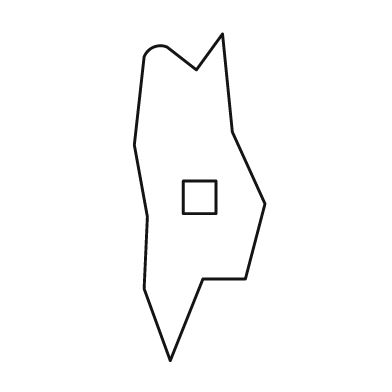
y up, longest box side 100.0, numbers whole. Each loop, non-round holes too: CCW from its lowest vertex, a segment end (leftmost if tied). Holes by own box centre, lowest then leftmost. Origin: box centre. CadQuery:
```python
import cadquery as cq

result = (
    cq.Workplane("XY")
    .moveTo(-9.0, -50.0)
    .lineTo(1.0, -25.0)
    .lineTo(14.0, -25.0)
    .lineTo(20.0, -2.0)
    .lineTo(10.0, 20.0)
    .lineTo(7.0, 50.0)
    .lineTo(-1.0, 39.0)
    .lineTo(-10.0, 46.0)
    .threePointArc((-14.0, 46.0), (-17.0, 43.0))
    .lineTo(-20.0, 16.0)
    .lineTo(-16.0, -6.0)
    .lineTo(-17.0, -28.0)
    .close()
    .moveTo(-5.0, -5.0)
    .lineTo(5.0, -5.0)
    .lineTo(5.0, 5.0)
    .lineTo(-5.0, 5.0)
    .close()
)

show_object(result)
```